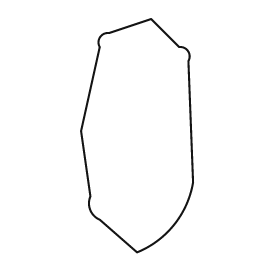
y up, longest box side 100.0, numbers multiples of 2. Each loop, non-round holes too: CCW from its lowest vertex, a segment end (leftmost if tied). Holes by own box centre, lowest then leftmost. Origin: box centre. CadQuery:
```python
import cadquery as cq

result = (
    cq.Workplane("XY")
    .moveTo(0.0, -50.0)
    .threePointArc((16.0, -38.0), (24.0, -20.0))
    .lineTo(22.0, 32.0)
    .threePointArc((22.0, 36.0), (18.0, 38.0))
    .lineTo(6.0, 50.0)
    .lineTo(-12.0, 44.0)
    .threePointArc((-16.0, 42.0), (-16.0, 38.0))
    .lineTo(-24.0, 2.0)
    .lineTo(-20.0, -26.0)
    .threePointArc((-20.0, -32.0), (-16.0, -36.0))
    .close()
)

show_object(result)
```